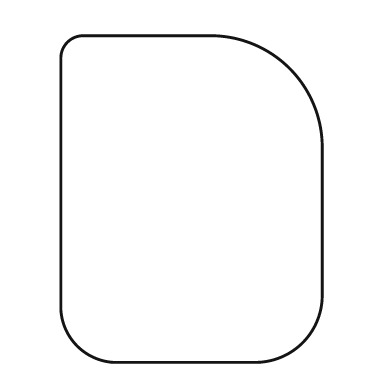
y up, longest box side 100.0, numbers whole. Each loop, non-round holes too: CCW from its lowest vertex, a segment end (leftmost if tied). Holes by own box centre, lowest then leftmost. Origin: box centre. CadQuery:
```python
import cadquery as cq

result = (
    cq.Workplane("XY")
    .moveTo(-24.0, -50.0)
    .lineTo(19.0, -50.0)
    .threePointArc((34.0, -44.0), (40.0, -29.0))
    .lineTo(40.0, 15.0)
    .threePointArc((30.0, 40.0), (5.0, 50.0))
    .lineTo(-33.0, 50.0)
    .threePointArc((-38.0, 48.0), (-40.0, 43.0))
    .lineTo(-40.0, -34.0)
    .threePointArc((-35.0, -45.0), (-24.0, -50.0))
    .close()
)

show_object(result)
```